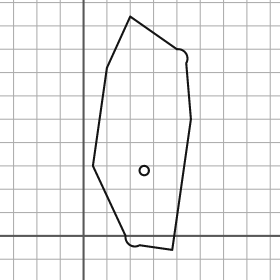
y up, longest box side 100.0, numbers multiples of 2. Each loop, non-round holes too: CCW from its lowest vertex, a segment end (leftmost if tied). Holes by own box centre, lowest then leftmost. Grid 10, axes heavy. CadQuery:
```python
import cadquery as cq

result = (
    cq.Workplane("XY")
    .moveTo(38.0, -6.0)
    .lineTo(46.0, 50.0)
    .lineTo(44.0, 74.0)
    .threePointArc((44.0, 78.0), (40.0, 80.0))
    .lineTo(20.0, 94.0)
    .lineTo(10.0, 72.0)
    .lineTo(4.0, 30.0)
    .lineTo(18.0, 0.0)
    .threePointArc((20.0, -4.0), (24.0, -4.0))
    .close()
    .moveTo(26.0, 28.0)
    .circle(2.0)
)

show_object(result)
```